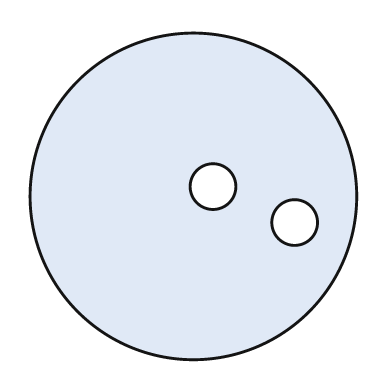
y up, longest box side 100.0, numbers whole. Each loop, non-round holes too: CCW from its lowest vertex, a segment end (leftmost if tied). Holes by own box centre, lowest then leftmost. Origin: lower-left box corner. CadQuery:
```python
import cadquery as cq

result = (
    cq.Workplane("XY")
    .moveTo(50.0, 50.0)
    .circle(50.0)
    .moveTo(81.0, 42.0)
    .circle(7.0)
    .moveTo(56.0, 53.0)
    .circle(7.0)
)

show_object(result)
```